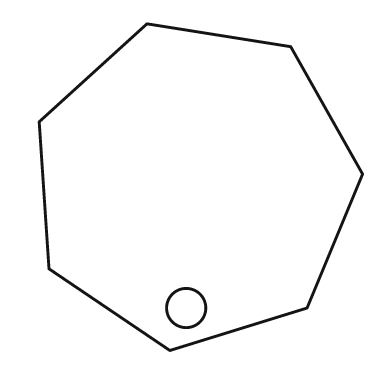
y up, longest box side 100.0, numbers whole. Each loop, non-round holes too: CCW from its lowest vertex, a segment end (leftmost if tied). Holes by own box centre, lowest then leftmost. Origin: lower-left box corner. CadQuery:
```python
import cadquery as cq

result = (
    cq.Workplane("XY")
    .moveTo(40.0, 0.0)
    .lineTo(82.0, 13.0)
    .lineTo(99.0, 54.0)
    .lineTo(77.0, 93.0)
    .lineTo(33.0, 100.0)
    .lineTo(0.0, 70.0)
    .lineTo(3.0, 25.0)
    .close()
    .moveTo(45.0, 13.0)
    .circle(6.0)
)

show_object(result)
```